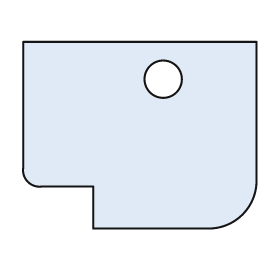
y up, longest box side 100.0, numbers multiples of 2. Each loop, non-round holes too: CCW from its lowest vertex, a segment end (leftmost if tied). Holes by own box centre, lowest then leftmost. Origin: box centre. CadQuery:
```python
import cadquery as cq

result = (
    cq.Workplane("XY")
    .moveTo(-20.0, -40.0)
    .lineTo(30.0, -40.0)
    .threePointArc((44.0, -34.0), (50.0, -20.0))
    .lineTo(50.0, 40.0)
    .lineTo(-50.0, 40.0)
    .lineTo(-50.0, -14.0)
    .threePointArc((-48.0, -20.0), (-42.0, -22.0))
    .lineTo(-20.0, -22.0)
    .close()
    .moveTo(10.0, 24.0)
    .circle(8.0)
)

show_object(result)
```